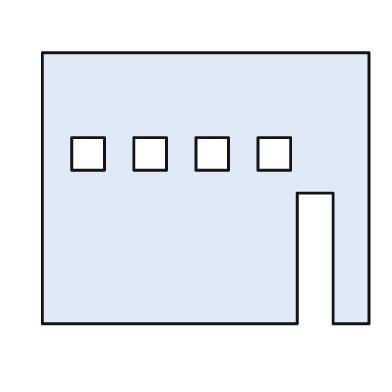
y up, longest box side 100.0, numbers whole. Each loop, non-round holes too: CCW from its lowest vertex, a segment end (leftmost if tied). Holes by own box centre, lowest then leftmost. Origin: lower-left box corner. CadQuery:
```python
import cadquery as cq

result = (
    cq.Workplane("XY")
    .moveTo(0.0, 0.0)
    .lineTo(78.0, 0.0)
    .lineTo(78.0, 40.0)
    .lineTo(89.0, 40.0)
    .lineTo(89.0, 0.0)
    .lineTo(100.0, 0.0)
    .lineTo(100.0, 83.0)
    .lineTo(0.0, 83.0)
    .close()
    .moveTo(9.0, 47.0)
    .lineTo(19.0, 47.0)
    .lineTo(19.0, 57.0)
    .lineTo(9.0, 57.0)
    .close()
    .moveTo(28.0, 47.0)
    .lineTo(38.0, 47.0)
    .lineTo(38.0, 57.0)
    .lineTo(28.0, 57.0)
    .close()
    .moveTo(47.0, 47.0)
    .lineTo(57.0, 47.0)
    .lineTo(57.0, 57.0)
    .lineTo(47.0, 57.0)
    .close()
    .moveTo(66.0, 47.0)
    .lineTo(76.0, 47.0)
    .lineTo(76.0, 57.0)
    .lineTo(66.0, 57.0)
    .close()
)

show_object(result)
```